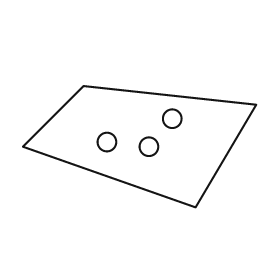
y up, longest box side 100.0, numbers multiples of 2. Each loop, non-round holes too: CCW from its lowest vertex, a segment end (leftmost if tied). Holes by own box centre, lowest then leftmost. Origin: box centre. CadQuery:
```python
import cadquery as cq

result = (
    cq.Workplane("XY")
    .moveTo(24.0, -26.0)
    .lineTo(50.0, 18.0)
    .lineTo(-24.0, 26.0)
    .lineTo(-50.0, 0.0)
    .close()
    .moveTo(4.0, 0.0)
    .circle(4.0)
    .moveTo(-14.0, 2.0)
    .circle(4.0)
    .moveTo(14.0, 12.0)
    .circle(4.0)
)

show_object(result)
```